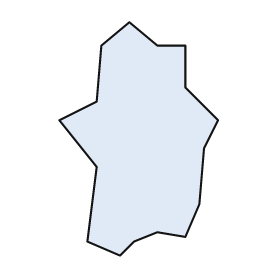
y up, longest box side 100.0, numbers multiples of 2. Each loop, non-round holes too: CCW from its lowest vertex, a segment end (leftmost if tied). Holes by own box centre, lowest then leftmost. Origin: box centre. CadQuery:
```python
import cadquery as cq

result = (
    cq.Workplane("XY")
    .moveTo(-8.0, -50.0)
    .lineTo(-2.0, -44.0)
    .lineTo(8.0, -40.0)
    .lineTo(20.0, -42.0)
    .lineTo(26.0, -28.0)
    .lineTo(28.0, -4.0)
    .lineTo(34.0, 8.0)
    .lineTo(20.0, 22.0)
    .lineTo(20.0, 40.0)
    .lineTo(8.0, 40.0)
    .lineTo(-4.0, 50.0)
    .lineTo(-16.0, 40.0)
    .lineTo(-18.0, 16.0)
    .lineTo(-34.0, 8.0)
    .lineTo(-18.0, -12.0)
    .lineTo(-22.0, -44.0)
    .close()
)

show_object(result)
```